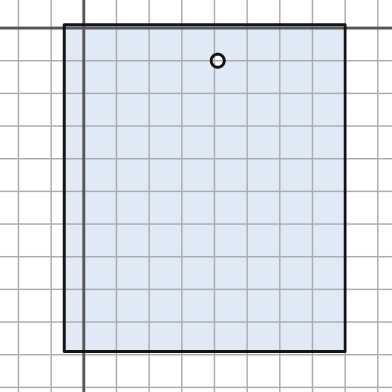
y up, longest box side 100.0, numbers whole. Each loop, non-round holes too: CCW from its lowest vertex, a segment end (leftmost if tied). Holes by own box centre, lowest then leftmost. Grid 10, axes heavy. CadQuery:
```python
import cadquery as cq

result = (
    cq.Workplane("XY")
    .moveTo(-6.0, -99.0)
    .lineTo(80.0, -99.0)
    .lineTo(80.0, 1.0)
    .lineTo(-6.0, 1.0)
    .close()
    .moveTo(41.0, -10.0)
    .circle(2.0)
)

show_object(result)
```